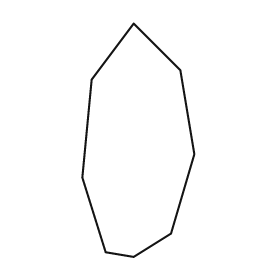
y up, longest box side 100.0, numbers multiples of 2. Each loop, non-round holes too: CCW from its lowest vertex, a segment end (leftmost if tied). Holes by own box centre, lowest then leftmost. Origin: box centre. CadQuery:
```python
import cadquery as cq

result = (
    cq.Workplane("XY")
    .moveTo(-2.0, -50.0)
    .lineTo(14.0, -40.0)
    .lineTo(24.0, -6.0)
    .lineTo(18.0, 30.0)
    .lineTo(-2.0, 50.0)
    .lineTo(-20.0, 26.0)
    .lineTo(-24.0, -16.0)
    .lineTo(-14.0, -48.0)
    .close()
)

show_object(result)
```